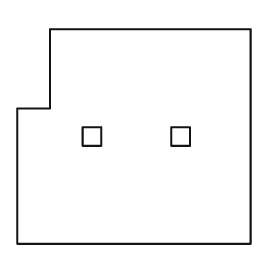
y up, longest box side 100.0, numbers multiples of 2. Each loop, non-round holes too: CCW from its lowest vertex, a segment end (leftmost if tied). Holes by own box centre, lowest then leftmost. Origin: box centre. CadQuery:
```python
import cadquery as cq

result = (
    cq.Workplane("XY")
    .moveTo(-50.0, -46.0)
    .lineTo(50.0, -46.0)
    .lineTo(50.0, 46.0)
    .lineTo(-36.0, 46.0)
    .lineTo(-36.0, 12.0)
    .lineTo(-50.0, 12.0)
    .close()
    .moveTo(-22.0, -4.0)
    .lineTo(-14.0, -4.0)
    .lineTo(-14.0, 4.0)
    .lineTo(-22.0, 4.0)
    .close()
    .moveTo(16.0, -4.0)
    .lineTo(24.0, -4.0)
    .lineTo(24.0, 4.0)
    .lineTo(16.0, 4.0)
    .close()
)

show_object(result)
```